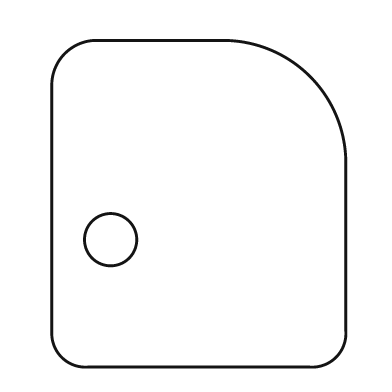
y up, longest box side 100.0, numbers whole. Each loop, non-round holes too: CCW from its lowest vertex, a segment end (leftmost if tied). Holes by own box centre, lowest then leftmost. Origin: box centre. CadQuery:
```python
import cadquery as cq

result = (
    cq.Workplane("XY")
    .moveTo(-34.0, -50.0)
    .lineTo(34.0, -50.0)
    .threePointArc((42.0, -47.0), (45.0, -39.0))
    .lineTo(45.0, 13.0)
    .threePointArc((34.0, 39.0), (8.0, 50.0))
    .lineTo(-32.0, 50.0)
    .threePointArc((-41.0, 46.0), (-45.0, 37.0))
    .lineTo(-45.0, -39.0)
    .threePointArc((-42.0, -47.0), (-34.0, -50.0))
    .close()
    .moveTo(-27.0, -11.0)
    .circle(8.0)
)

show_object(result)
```